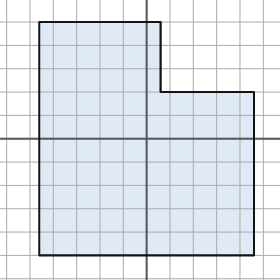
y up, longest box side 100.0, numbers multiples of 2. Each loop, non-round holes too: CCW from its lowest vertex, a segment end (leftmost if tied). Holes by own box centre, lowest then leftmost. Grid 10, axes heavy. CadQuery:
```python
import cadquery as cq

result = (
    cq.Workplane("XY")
    .moveTo(-46.0, -50.0)
    .lineTo(46.0, -50.0)
    .lineTo(46.0, 20.0)
    .lineTo(6.0, 20.0)
    .lineTo(6.0, 50.0)
    .lineTo(-46.0, 50.0)
    .close()
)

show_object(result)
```